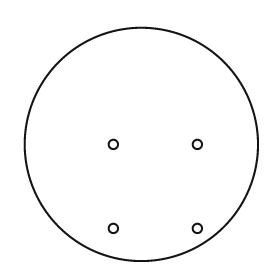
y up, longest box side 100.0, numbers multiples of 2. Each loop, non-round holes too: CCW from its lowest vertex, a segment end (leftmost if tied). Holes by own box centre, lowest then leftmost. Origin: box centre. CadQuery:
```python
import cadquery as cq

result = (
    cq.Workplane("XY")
    .moveTo(0.0, 0.0)
    .circle(50.0)
    .moveTo(-12.0, -36.0)
    .circle(2.0)
    .moveTo(24.0, -36.0)
    .circle(2.0)
    .moveTo(-12.0, 0.0)
    .circle(2.0)
    .moveTo(24.0, 0.0)
    .circle(2.0)
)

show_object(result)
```